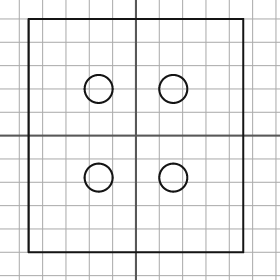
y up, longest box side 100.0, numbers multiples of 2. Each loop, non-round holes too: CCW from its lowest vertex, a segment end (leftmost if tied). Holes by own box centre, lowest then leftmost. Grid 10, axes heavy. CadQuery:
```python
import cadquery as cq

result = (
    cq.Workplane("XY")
    .moveTo(-46.0, -50.0)
    .lineTo(46.0, -50.0)
    .lineTo(46.0, 50.0)
    .lineTo(-46.0, 50.0)
    .close()
    .moveTo(-16.0, -18.0)
    .circle(6.0)
    .moveTo(16.0, -18.0)
    .circle(6.0)
    .moveTo(-16.0, 20.0)
    .circle(6.0)
    .moveTo(16.0, 20.0)
    .circle(6.0)
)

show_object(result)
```